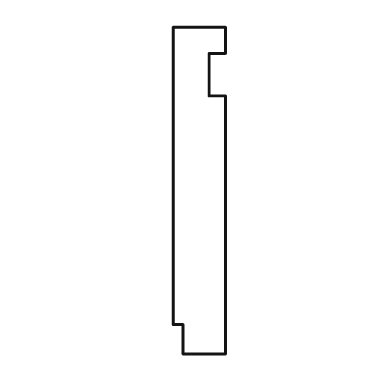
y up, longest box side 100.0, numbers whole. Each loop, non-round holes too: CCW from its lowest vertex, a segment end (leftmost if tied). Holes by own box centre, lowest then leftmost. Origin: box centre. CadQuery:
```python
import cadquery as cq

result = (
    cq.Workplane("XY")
    .moveTo(-5.0, -50.0)
    .lineTo(8.0, -50.0)
    .lineTo(8.0, 29.0)
    .lineTo(3.0, 29.0)
    .lineTo(3.0, 42.0)
    .lineTo(8.0, 42.0)
    .lineTo(8.0, 50.0)
    .lineTo(-8.0, 50.0)
    .lineTo(-8.0, -41.0)
    .lineTo(-5.0, -41.0)
    .close()
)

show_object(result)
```